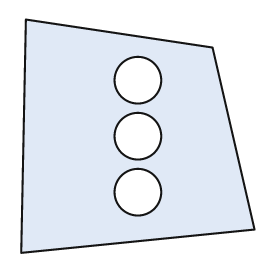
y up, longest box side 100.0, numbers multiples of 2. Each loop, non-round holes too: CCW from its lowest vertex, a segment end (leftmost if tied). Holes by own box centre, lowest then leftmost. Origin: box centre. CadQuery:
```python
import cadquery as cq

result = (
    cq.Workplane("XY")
    .moveTo(-50.0, -50.0)
    .lineTo(50.0, -40.0)
    .lineTo(32.0, 38.0)
    .lineTo(-48.0, 50.0)
    .close()
    .moveTo(0.0, -24.0)
    .circle(10.0)
    .moveTo(0.0, 0.0)
    .circle(10.0)
    .moveTo(0.0, 24.0)
    .circle(10.0)
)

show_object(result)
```